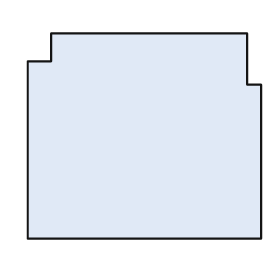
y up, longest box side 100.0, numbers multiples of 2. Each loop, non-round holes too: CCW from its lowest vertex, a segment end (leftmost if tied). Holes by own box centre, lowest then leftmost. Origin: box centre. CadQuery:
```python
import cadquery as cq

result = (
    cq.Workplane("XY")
    .moveTo(-50.0, -44.0)
    .lineTo(50.0, -44.0)
    .lineTo(50.0, 22.0)
    .lineTo(44.0, 22.0)
    .lineTo(44.0, 44.0)
    .lineTo(-40.0, 44.0)
    .lineTo(-40.0, 32.0)
    .lineTo(-50.0, 32.0)
    .close()
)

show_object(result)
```